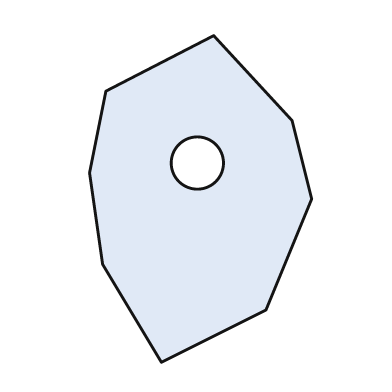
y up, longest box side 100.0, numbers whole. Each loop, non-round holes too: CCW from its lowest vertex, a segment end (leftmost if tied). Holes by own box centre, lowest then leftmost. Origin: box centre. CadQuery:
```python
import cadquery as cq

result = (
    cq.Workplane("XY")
    .moveTo(-12.0, -50.0)
    .lineTo(20.0, -34.0)
    .lineTo(34.0, 0.0)
    .lineTo(28.0, 24.0)
    .lineTo(4.0, 50.0)
    .lineTo(-29.0, 33.0)
    .lineTo(-34.0, 8.0)
    .lineTo(-30.0, -20.0)
    .close()
    .moveTo(-1.0, 11.0)
    .circle(8.0)
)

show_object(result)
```